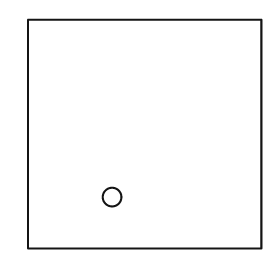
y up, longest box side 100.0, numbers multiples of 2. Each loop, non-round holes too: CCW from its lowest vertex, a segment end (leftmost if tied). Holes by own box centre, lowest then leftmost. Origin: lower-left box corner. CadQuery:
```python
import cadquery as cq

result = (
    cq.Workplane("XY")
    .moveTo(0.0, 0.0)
    .lineTo(100.0, 0.0)
    .lineTo(100.0, 98.0)
    .lineTo(0.0, 98.0)
    .close()
    .moveTo(36.0, 22.0)
    .circle(4.0)
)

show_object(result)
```